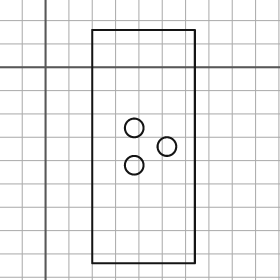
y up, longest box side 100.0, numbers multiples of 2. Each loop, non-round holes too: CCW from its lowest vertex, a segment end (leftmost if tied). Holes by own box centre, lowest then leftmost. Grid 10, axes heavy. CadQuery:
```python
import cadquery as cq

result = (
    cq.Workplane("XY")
    .moveTo(20.0, -84.0)
    .lineTo(64.0, -84.0)
    .lineTo(64.0, 16.0)
    .lineTo(20.0, 16.0)
    .close()
    .moveTo(38.0, -42.0)
    .circle(4.0)
    .moveTo(52.0, -34.0)
    .circle(4.0)
    .moveTo(38.0, -26.0)
    .circle(4.0)
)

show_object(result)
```